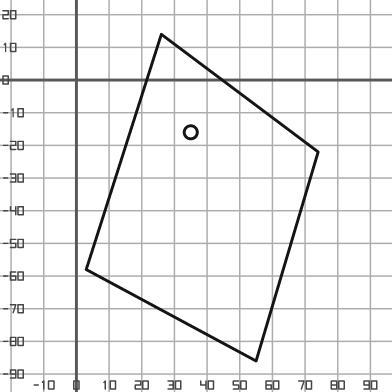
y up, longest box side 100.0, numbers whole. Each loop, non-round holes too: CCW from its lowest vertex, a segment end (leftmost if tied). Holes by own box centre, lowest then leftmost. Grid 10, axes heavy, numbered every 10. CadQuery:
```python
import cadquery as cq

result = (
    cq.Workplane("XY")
    .moveTo(55.0, -86.0)
    .lineTo(74.0, -22.0)
    .lineTo(26.0, 14.0)
    .lineTo(3.0, -58.0)
    .close()
    .moveTo(35.0, -16.0)
    .circle(2.0)
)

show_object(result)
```